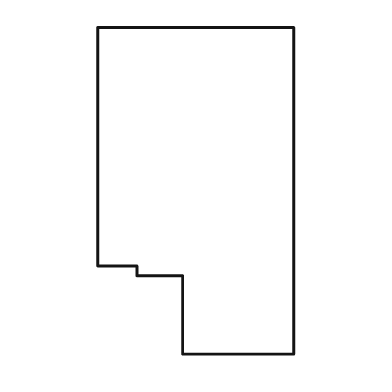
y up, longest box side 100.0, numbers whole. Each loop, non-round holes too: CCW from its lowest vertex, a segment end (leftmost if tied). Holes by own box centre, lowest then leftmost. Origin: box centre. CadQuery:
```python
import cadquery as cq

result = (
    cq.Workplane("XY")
    .moveTo(-4.0, -50.0)
    .lineTo(30.0, -50.0)
    .lineTo(30.0, 50.0)
    .lineTo(-30.0, 50.0)
    .lineTo(-30.0, -23.0)
    .lineTo(-18.0, -23.0)
    .lineTo(-18.0, -26.0)
    .lineTo(-4.0, -26.0)
    .close()
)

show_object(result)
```